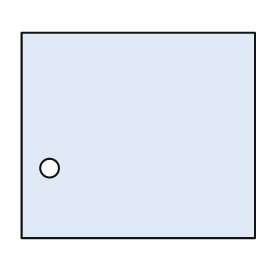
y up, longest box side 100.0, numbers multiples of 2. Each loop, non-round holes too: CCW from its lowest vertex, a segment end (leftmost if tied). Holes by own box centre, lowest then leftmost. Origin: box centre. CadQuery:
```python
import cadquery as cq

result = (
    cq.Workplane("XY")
    .moveTo(-50.0, -44.0)
    .lineTo(50.0, -44.0)
    .lineTo(50.0, 44.0)
    .lineTo(-50.0, 44.0)
    .close()
    .moveTo(-38.0, -14.0)
    .circle(4.0)
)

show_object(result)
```